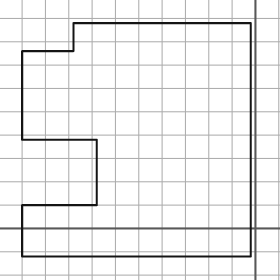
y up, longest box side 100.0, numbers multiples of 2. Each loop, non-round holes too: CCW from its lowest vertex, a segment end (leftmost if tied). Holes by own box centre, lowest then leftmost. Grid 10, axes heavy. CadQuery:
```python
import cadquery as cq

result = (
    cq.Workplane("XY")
    .moveTo(-100.0, -12.0)
    .lineTo(-2.0, -12.0)
    .lineTo(-2.0, 88.0)
    .lineTo(-78.0, 88.0)
    .lineTo(-78.0, 76.0)
    .lineTo(-100.0, 76.0)
    .lineTo(-100.0, 38.0)
    .lineTo(-68.0, 38.0)
    .lineTo(-68.0, 10.0)
    .lineTo(-100.0, 10.0)
    .close()
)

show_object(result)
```